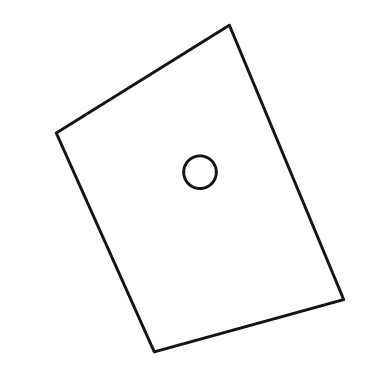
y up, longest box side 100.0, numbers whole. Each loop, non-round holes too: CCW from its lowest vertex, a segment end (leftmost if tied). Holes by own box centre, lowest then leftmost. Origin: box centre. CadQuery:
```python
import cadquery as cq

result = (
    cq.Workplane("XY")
    .moveTo(-14.0, -50.0)
    .lineTo(44.0, -34.0)
    .lineTo(9.0, 50.0)
    .lineTo(-44.0, 17.0)
    .close()
    .moveTo(0.0, 5.0)
    .circle(5.0)
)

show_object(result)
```